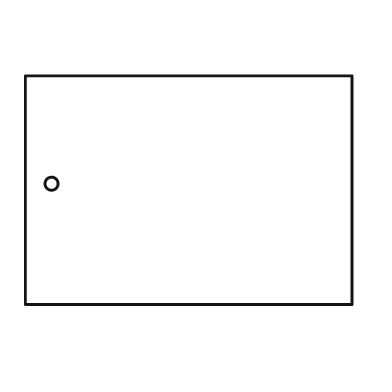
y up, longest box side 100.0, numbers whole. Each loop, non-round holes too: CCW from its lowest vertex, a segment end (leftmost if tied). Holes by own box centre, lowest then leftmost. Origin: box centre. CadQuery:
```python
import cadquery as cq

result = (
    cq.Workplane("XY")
    .moveTo(-50.0, -35.0)
    .lineTo(50.0, -35.0)
    .lineTo(50.0, 35.0)
    .lineTo(-50.0, 35.0)
    .close()
    .moveTo(-42.0, 2.0)
    .circle(2.0)
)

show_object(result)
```